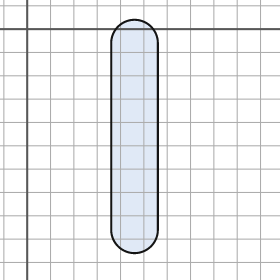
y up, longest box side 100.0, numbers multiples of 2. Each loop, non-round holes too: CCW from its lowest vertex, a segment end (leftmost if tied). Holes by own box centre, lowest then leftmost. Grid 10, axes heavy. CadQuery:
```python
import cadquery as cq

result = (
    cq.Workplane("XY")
    .moveTo(36.0, -86.0)
    .threePointArc((46.0, -96.0), (56.0, -86.0))
    .lineTo(56.0, -6.0)
    .threePointArc((46.0, 4.0), (36.0, -6.0))
    .close()
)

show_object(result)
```